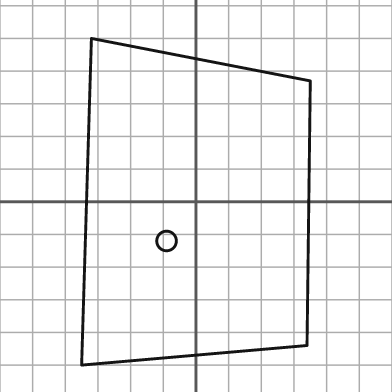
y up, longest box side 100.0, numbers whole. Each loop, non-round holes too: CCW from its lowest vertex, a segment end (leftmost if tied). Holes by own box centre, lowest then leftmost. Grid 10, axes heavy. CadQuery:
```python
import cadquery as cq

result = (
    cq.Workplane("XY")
    .moveTo(-35.0, -50.0)
    .lineTo(34.0, -44.0)
    .lineTo(35.0, 37.0)
    .lineTo(-32.0, 50.0)
    .close()
    .moveTo(-9.0, -12.0)
    .circle(3.0)
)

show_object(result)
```